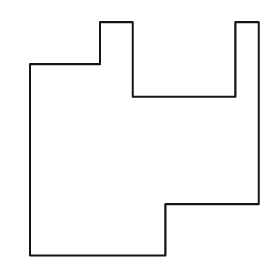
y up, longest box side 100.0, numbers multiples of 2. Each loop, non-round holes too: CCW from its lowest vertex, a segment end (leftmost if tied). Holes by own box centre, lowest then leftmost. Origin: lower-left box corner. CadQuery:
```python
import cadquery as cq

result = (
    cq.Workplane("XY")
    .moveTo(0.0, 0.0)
    .lineTo(58.0, 0.0)
    .lineTo(58.0, 22.0)
    .lineTo(98.0, 22.0)
    .lineTo(98.0, 100.0)
    .lineTo(88.0, 100.0)
    .lineTo(88.0, 68.0)
    .lineTo(44.0, 68.0)
    .lineTo(44.0, 100.0)
    .lineTo(30.0, 100.0)
    .lineTo(30.0, 82.0)
    .lineTo(0.0, 82.0)
    .close()
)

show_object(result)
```